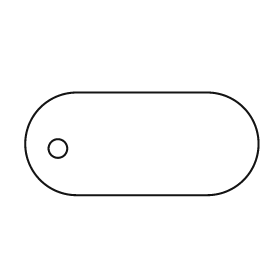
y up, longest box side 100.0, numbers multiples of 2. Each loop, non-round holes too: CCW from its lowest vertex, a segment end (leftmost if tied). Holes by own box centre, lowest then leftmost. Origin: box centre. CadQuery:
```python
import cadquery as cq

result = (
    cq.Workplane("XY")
    .moveTo(-28.0, -22.0)
    .lineTo(28.0, -22.0)
    .threePointArc((50.0, 0.0), (28.0, 22.0))
    .lineTo(-28.0, 22.0)
    .threePointArc((-50.0, 0.0), (-28.0, -22.0))
    .close()
    .moveTo(-36.0, -2.0)
    .circle(4.0)
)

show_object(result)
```